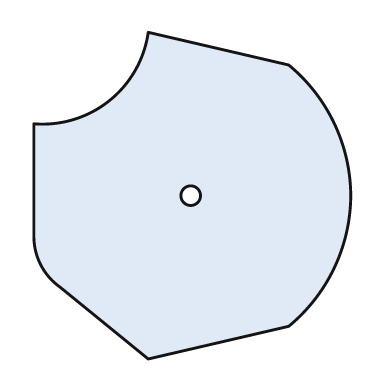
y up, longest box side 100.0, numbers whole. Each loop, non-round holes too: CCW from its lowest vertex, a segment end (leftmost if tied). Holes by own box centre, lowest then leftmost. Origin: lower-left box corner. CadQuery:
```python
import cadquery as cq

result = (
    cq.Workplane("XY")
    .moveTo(35.0, 0.0)
    .lineTo(78.0, 10.0)
    .threePointArc((92.0, 28.0), (97.0, 50.0))
    .threePointArc((92.0, 72.0), (78.0, 90.0))
    .lineTo(35.0, 100.0)
    .threePointArc((23.0, 79.0), (0.0, 72.0))
    .lineTo(0.0, 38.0)
    .threePointArc((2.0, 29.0), (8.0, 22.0))
    .close()
    .moveTo(48.0, 50.0)
    .circle(3.0)
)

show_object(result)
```